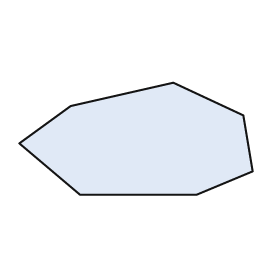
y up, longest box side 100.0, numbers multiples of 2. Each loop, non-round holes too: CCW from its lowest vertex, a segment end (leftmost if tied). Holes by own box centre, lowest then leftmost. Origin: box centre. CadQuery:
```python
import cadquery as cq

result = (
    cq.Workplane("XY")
    .moveTo(-24.0, -24.0)
    .lineTo(26.0, -24.0)
    .lineTo(50.0, -14.0)
    .lineTo(46.0, 10.0)
    .lineTo(16.0, 24.0)
    .lineTo(-28.0, 14.0)
    .lineTo(-50.0, -2.0)
    .close()
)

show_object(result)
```